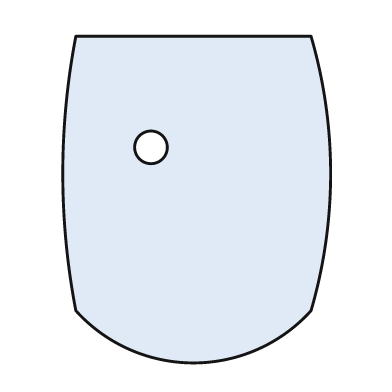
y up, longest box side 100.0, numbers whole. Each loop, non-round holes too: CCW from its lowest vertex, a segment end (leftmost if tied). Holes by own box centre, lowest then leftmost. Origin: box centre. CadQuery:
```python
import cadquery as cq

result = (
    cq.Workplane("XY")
    .moveTo(-37.0, -34.0)
    .threePointArc((-1.0, -50.0), (35.0, -34.0))
    .threePointArc((41.0, 8.0), (35.0, 50.0))
    .lineTo(-37.0, 50.0)
    .threePointArc((-41.0, 8.0), (-37.0, -34.0))
    .close()
    .moveTo(-14.0, 16.0)
    .circle(5.0)
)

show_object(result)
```